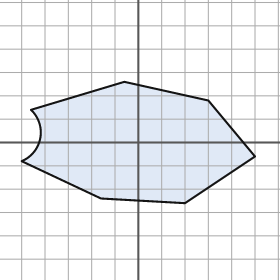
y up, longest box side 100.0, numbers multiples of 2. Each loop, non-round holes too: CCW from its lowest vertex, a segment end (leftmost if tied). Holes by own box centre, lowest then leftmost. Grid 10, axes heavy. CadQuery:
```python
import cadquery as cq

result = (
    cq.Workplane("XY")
    .moveTo(20.0, -26.0)
    .lineTo(50.0, -6.0)
    .lineTo(30.0, 18.0)
    .lineTo(-6.0, 26.0)
    .lineTo(-46.0, 14.0)
    .threePointArc((-42.0, 2.0), (-50.0, -8.0))
    .lineTo(-16.0, -24.0)
    .close()
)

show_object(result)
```